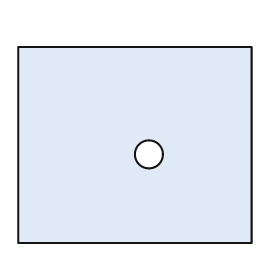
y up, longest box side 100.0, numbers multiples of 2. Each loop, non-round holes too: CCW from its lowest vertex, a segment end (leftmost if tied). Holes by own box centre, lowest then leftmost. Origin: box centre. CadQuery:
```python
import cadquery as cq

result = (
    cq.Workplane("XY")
    .moveTo(-50.0, -42.0)
    .lineTo(50.0, -42.0)
    .lineTo(50.0, 42.0)
    .lineTo(-50.0, 42.0)
    .close()
    .moveTo(6.0, -4.0)
    .circle(6.0)
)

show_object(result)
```